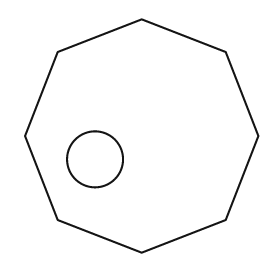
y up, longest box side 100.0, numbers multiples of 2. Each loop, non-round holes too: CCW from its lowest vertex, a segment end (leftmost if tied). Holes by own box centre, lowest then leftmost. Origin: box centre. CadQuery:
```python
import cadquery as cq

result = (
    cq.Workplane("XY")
    .moveTo(0.0, -50.0)
    .lineTo(36.0, -36.0)
    .lineTo(50.0, 0.0)
    .lineTo(36.0, 36.0)
    .lineTo(0.0, 50.0)
    .lineTo(-36.0, 36.0)
    .lineTo(-50.0, 0.0)
    .lineTo(-36.0, -36.0)
    .close()
    .moveTo(-20.0, -10.0)
    .circle(12.0)
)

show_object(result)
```